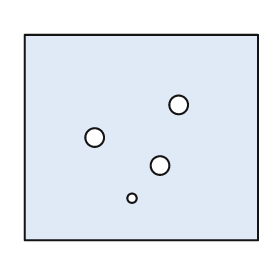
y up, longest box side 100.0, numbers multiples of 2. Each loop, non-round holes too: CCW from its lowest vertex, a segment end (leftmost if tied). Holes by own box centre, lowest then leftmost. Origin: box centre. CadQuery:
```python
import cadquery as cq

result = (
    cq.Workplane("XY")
    .moveTo(-50.0, -44.0)
    .lineTo(50.0, -44.0)
    .lineTo(50.0, 44.0)
    .lineTo(-50.0, 44.0)
    .close()
    .moveTo(-4.0, -26.0)
    .circle(2.0)
    .moveTo(8.0, -12.0)
    .circle(4.0)
    .moveTo(-20.0, 0.0)
    .circle(4.0)
    .moveTo(16.0, 14.0)
    .circle(4.0)
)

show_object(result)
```